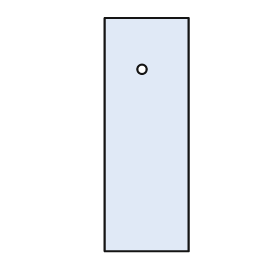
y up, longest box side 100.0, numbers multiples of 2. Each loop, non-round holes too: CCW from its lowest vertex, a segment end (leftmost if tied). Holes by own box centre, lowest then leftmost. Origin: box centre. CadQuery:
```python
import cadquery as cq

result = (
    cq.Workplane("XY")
    .moveTo(-18.0, -50.0)
    .lineTo(18.0, -50.0)
    .lineTo(18.0, 50.0)
    .lineTo(-18.0, 50.0)
    .close()
    .moveTo(-2.0, 28.0)
    .circle(2.0)
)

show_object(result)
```